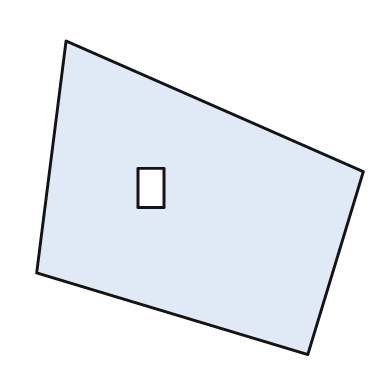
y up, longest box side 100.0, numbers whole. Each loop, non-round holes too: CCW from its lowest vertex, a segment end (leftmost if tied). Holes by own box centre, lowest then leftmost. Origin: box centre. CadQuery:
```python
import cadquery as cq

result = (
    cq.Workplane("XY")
    .moveTo(33.0, -48.0)
    .lineTo(50.0, 8.0)
    .lineTo(-41.0, 48.0)
    .lineTo(-50.0, -23.0)
    .close()
    .moveTo(-19.0, -3.0)
    .lineTo(-11.0, -3.0)
    .lineTo(-11.0, 9.0)
    .lineTo(-19.0, 9.0)
    .close()
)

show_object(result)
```